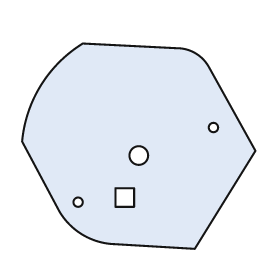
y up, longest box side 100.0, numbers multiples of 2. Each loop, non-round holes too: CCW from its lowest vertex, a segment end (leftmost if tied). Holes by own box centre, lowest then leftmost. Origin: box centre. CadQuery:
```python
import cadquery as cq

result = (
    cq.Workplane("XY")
    .moveTo(24.0, -44.0)
    .lineTo(50.0, -2.0)
    .lineTo(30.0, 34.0)
    .threePointArc((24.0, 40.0), (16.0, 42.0))
    .lineTo(-24.0, 44.0)
    .threePointArc((-42.0, 26.0), (-50.0, 2.0))
    .lineTo(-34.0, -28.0)
    .threePointArc((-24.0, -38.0), (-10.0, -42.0))
    .close()
    .moveTo(-26.0, -24.0)
    .circle(2.0)
    .moveTo(-10.0, -26.0)
    .lineTo(-2.0, -26.0)
    .lineTo(-2.0, -18.0)
    .lineTo(-10.0, -18.0)
    .close()
    .moveTo(0.0, -4.0)
    .circle(4.0)
    .moveTo(32.0, 8.0)
    .circle(2.0)
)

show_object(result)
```